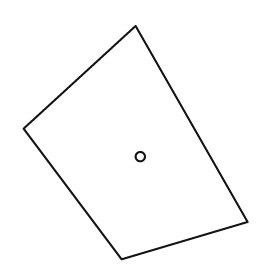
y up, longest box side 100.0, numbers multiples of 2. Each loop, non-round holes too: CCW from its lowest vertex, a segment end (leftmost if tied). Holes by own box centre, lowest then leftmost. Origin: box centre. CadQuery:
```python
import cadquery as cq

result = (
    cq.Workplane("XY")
    .moveTo(-6.0, -50.0)
    .lineTo(48.0, -34.0)
    .lineTo(0.0, 50.0)
    .lineTo(-48.0, 6.0)
    .close()
    .moveTo(2.0, -6.0)
    .circle(2.0)
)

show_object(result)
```